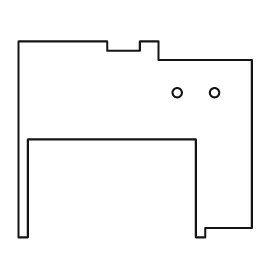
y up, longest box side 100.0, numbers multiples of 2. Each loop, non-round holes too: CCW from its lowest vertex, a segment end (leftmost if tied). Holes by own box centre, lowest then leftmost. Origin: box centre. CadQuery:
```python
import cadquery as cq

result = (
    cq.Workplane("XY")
    .moveTo(-50.0, -42.0)
    .lineTo(-46.0, -42.0)
    .lineTo(-46.0, 0.0)
    .lineTo(26.0, 0.0)
    .lineTo(26.0, -42.0)
    .lineTo(30.0, -42.0)
    .lineTo(30.0, -38.0)
    .lineTo(50.0, -38.0)
    .lineTo(50.0, 34.0)
    .lineTo(10.0, 34.0)
    .lineTo(10.0, 42.0)
    .lineTo(2.0, 42.0)
    .lineTo(2.0, 38.0)
    .lineTo(-12.0, 38.0)
    .lineTo(-12.0, 42.0)
    .lineTo(-50.0, 42.0)
    .close()
    .moveTo(18.0, 20.0)
    .circle(2.0)
    .moveTo(34.0, 20.0)
    .circle(2.0)
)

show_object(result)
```